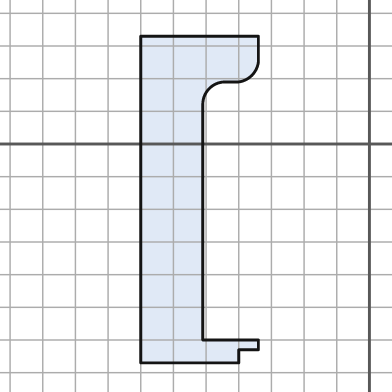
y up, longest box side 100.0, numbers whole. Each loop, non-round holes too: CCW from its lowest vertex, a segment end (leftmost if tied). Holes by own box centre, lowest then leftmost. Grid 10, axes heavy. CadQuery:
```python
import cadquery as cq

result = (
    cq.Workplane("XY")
    .moveTo(-70.0, -67.0)
    .lineTo(-40.0, -67.0)
    .lineTo(-40.0, -63.0)
    .lineTo(-34.0, -63.0)
    .lineTo(-34.0, -60.0)
    .lineTo(-51.0, -60.0)
    .lineTo(-51.0, 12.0)
    .threePointArc((-49.0, 17.0), (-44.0, 19.0))
    .lineTo(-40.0, 19.0)
    .threePointArc((-36.0, 21.0), (-34.0, 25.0))
    .lineTo(-34.0, 33.0)
    .lineTo(-70.0, 33.0)
    .close()
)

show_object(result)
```